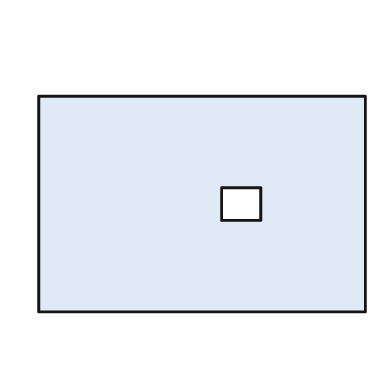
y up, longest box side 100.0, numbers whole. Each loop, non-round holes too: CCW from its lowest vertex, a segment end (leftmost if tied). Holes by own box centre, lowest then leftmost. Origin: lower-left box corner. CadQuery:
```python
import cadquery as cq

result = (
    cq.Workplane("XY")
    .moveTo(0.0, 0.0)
    .lineTo(100.0, 0.0)
    .lineTo(100.0, 66.0)
    .lineTo(0.0, 66.0)
    .close()
    .moveTo(56.0, 28.0)
    .lineTo(68.0, 28.0)
    .lineTo(68.0, 38.0)
    .lineTo(56.0, 38.0)
    .close()
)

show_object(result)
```